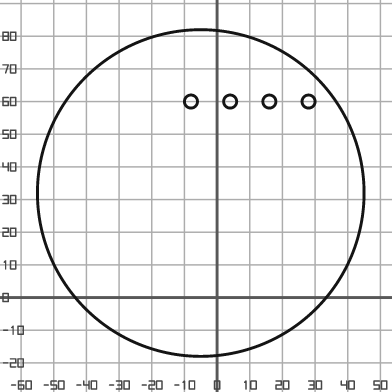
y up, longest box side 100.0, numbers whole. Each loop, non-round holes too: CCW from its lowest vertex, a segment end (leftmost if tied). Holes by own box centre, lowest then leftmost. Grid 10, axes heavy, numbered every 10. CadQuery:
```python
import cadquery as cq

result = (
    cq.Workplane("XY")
    .moveTo(-5.0, 32.0)
    .circle(50.0)
    .moveTo(-8.0, 60.0)
    .circle(2.0)
    .moveTo(4.0, 60.0)
    .circle(2.0)
    .moveTo(16.0, 60.0)
    .circle(2.0)
    .moveTo(28.0, 60.0)
    .circle(2.0)
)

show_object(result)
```